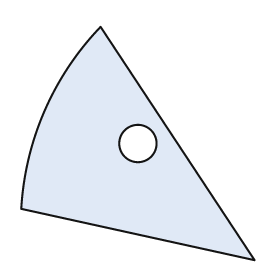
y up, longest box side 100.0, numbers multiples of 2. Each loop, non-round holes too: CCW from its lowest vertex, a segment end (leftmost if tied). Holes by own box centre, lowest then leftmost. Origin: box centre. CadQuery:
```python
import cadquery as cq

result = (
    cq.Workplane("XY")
    .moveTo(50.0, -50.0)
    .lineTo(-16.0, 50.0)
    .threePointArc((-40.0, 14.0), (-50.0, -28.0))
    .close()
    .moveTo(0.0, 0.0)
    .circle(8.0)
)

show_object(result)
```